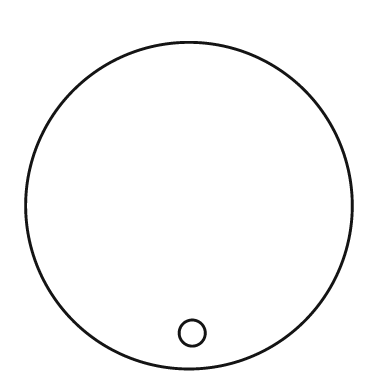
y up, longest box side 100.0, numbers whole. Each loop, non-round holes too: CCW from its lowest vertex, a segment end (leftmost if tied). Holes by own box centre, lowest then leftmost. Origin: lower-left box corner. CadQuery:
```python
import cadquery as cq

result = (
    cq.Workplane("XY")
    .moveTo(50.0, 50.0)
    .circle(50.0)
    .moveTo(51.0, 11.0)
    .circle(4.0)
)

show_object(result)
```